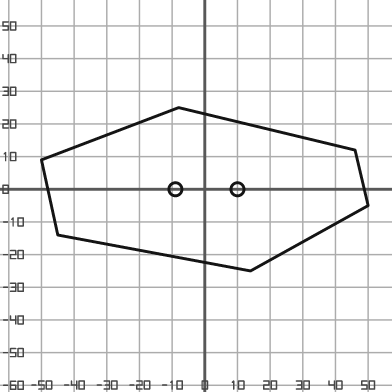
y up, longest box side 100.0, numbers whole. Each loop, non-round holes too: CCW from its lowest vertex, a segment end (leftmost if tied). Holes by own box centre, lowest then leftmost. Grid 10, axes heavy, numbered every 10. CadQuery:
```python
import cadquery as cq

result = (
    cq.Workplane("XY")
    .moveTo(14.0, -25.0)
    .lineTo(50.0, -5.0)
    .lineTo(46.0, 12.0)
    .lineTo(-8.0, 25.0)
    .lineTo(-50.0, 9.0)
    .lineTo(-45.0, -14.0)
    .close()
    .moveTo(-9.0, 0.0)
    .circle(2.0)
    .moveTo(10.0, 0.0)
    .circle(2.0)
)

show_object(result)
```